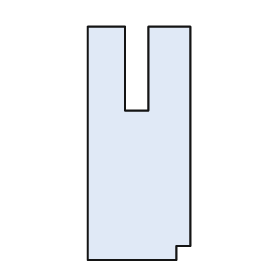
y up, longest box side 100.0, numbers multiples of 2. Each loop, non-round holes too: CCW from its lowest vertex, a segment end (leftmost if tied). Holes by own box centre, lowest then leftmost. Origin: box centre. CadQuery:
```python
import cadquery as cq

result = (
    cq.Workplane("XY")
    .moveTo(-22.0, -50.0)
    .lineTo(16.0, -50.0)
    .lineTo(16.0, -44.0)
    .lineTo(22.0, -44.0)
    .lineTo(22.0, 50.0)
    .lineTo(4.0, 50.0)
    .lineTo(4.0, 14.0)
    .lineTo(-6.0, 14.0)
    .lineTo(-6.0, 50.0)
    .lineTo(-22.0, 50.0)
    .close()
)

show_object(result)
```